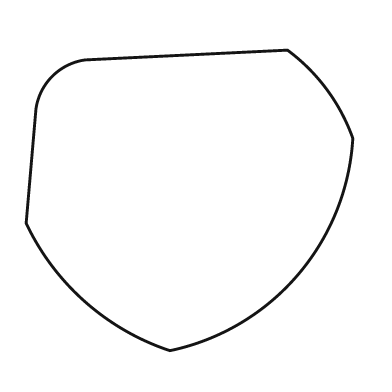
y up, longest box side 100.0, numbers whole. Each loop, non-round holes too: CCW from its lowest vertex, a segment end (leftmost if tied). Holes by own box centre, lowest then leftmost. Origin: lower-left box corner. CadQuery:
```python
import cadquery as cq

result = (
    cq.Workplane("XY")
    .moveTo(44.0, 0.0)
    .threePointArc((83.0, 23.0), (100.0, 65.0))
    .threePointArc((92.0, 80.0), (80.0, 92.0))
    .lineTo(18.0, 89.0)
    .threePointArc((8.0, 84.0), (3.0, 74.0))
    .lineTo(0.0, 39.0)
    .threePointArc((18.0, 15.0), (44.0, 0.0))
    .close()
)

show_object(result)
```